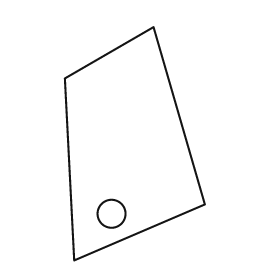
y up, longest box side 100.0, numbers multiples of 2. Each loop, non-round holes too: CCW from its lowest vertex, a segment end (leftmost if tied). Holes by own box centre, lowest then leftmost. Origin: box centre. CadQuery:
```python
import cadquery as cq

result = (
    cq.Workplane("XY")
    .moveTo(-26.0, -50.0)
    .lineTo(30.0, -26.0)
    .lineTo(8.0, 50.0)
    .lineTo(-30.0, 28.0)
    .close()
    .moveTo(-10.0, -30.0)
    .circle(6.0)
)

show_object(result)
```